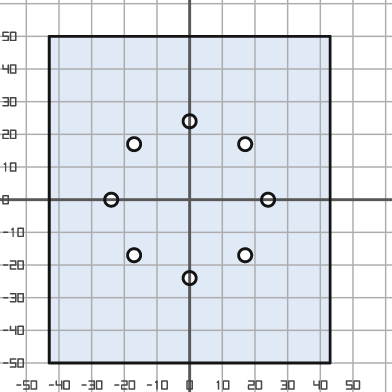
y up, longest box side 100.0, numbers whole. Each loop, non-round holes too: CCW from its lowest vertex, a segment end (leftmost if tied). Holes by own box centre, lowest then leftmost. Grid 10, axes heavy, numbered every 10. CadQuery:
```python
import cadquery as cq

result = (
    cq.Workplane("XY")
    .moveTo(-43.0, -50.0)
    .lineTo(43.0, -50.0)
    .lineTo(43.0, 50.0)
    .lineTo(-43.0, 50.0)
    .close()
    .moveTo(0.0, -24.0)
    .circle(2.0)
    .moveTo(-17.0, -17.0)
    .circle(2.0)
    .moveTo(17.0, -17.0)
    .circle(2.0)
    .moveTo(-24.0, 0.0)
    .circle(2.0)
    .moveTo(24.0, 0.0)
    .circle(2.0)
    .moveTo(-17.0, 17.0)
    .circle(2.0)
    .moveTo(17.0, 17.0)
    .circle(2.0)
    .moveTo(0.0, 24.0)
    .circle(2.0)
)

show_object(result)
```